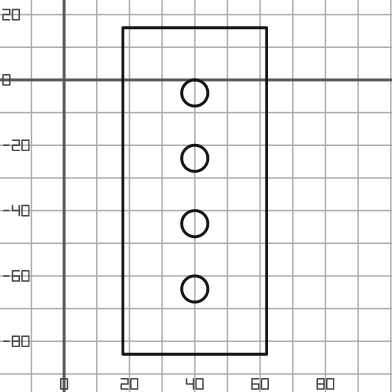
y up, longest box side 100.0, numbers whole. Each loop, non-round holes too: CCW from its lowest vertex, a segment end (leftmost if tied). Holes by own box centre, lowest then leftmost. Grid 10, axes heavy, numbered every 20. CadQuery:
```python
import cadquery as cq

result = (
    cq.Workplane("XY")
    .moveTo(18.0, -84.0)
    .lineTo(62.0, -84.0)
    .lineTo(62.0, 16.0)
    .lineTo(18.0, 16.0)
    .close()
    .moveTo(40.0, -64.0)
    .circle(4.0)
    .moveTo(40.0, -44.0)
    .circle(4.0)
    .moveTo(40.0, -24.0)
    .circle(4.0)
    .moveTo(40.0, -4.0)
    .circle(4.0)
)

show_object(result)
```